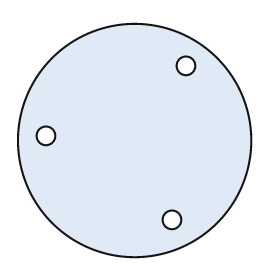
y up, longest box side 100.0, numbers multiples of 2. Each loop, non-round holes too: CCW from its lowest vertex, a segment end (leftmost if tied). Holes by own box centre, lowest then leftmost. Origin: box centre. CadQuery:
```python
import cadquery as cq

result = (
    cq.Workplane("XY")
    .moveTo(0.0, 0.0)
    .circle(50.0)
    .moveTo(16.0, -34.0)
    .circle(4.0)
    .moveTo(-38.0, 2.0)
    .circle(4.0)
    .moveTo(22.0, 32.0)
    .circle(4.0)
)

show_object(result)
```